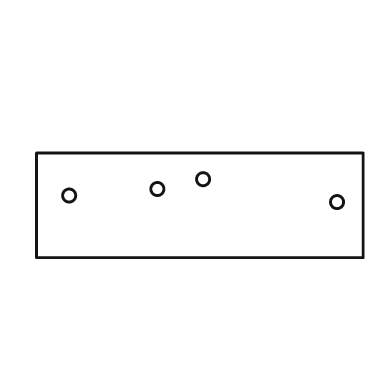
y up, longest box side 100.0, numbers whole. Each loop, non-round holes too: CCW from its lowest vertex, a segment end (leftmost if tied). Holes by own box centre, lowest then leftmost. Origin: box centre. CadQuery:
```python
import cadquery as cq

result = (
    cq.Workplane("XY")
    .moveTo(-50.0, -16.0)
    .lineTo(50.0, -16.0)
    .lineTo(50.0, 16.0)
    .lineTo(-50.0, 16.0)
    .close()
    .moveTo(42.0, 1.0)
    .circle(2.0)
    .moveTo(-40.0, 3.0)
    .circle(2.0)
    .moveTo(-13.0, 5.0)
    .circle(2.0)
    .moveTo(1.0, 8.0)
    .circle(2.0)
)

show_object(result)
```